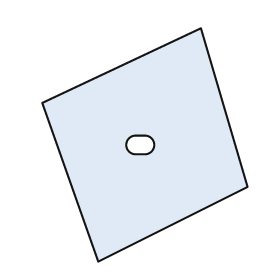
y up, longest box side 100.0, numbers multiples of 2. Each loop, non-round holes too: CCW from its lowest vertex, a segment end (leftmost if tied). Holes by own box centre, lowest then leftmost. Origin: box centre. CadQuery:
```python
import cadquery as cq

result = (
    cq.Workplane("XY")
    .moveTo(-20.0, -50.0)
    .lineTo(44.0, -18.0)
    .lineTo(24.0, 50.0)
    .lineTo(-44.0, 18.0)
    .close()
    .moveTo(-4.0, -4.0)
    .lineTo(0.0, -4.0)
    .threePointArc((4.0, 0.0), (0.0, 4.0))
    .lineTo(-4.0, 4.0)
    .threePointArc((-8.0, 0.0), (-4.0, -4.0))
    .close()
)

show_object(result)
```